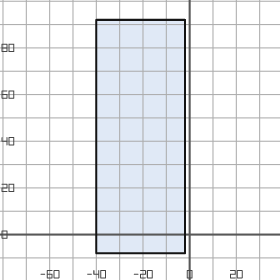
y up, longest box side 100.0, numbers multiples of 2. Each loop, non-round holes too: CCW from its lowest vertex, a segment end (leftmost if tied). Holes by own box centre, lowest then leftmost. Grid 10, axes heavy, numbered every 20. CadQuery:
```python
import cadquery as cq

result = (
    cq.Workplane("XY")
    .moveTo(-40.0, -8.0)
    .lineTo(-2.0, -8.0)
    .lineTo(-2.0, 92.0)
    .lineTo(-40.0, 92.0)
    .close()
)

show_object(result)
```